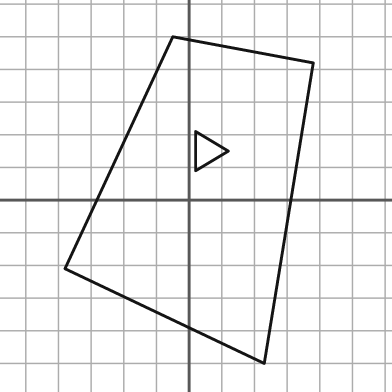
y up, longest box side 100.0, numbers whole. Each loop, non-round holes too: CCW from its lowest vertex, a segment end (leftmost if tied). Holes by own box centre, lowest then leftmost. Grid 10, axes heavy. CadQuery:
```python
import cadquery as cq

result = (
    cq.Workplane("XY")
    .moveTo(23.0, -50.0)
    .lineTo(38.0, 42.0)
    .lineTo(-5.0, 50.0)
    .lineTo(-38.0, -21.0)
    .close()
    .moveTo(2.0, 9.0)
    .lineTo(12.0, 15.0)
    .lineTo(2.0, 21.0)
    .close()
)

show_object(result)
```